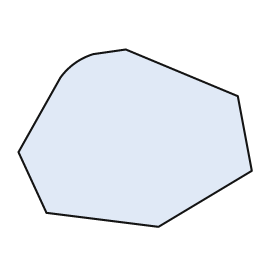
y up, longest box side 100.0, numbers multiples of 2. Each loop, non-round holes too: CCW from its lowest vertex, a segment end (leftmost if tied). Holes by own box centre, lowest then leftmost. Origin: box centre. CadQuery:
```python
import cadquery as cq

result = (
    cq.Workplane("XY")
    .moveTo(10.0, -38.0)
    .lineTo(50.0, -14.0)
    .lineTo(44.0, 18.0)
    .lineTo(-4.0, 38.0)
    .lineTo(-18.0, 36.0)
    .threePointArc((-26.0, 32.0), (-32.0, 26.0))
    .lineTo(-50.0, -6.0)
    .lineTo(-38.0, -32.0)
    .close()
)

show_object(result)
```